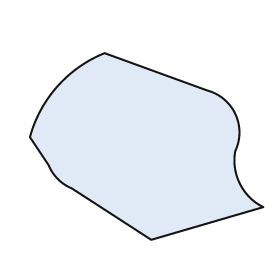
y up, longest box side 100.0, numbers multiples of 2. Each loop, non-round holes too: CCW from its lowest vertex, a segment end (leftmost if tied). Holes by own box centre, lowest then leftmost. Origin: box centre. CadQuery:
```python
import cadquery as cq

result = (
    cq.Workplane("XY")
    .moveTo(2.0, -40.0)
    .lineTo(50.0, -26.0)
    .threePointArc((40.0, -16.0), (38.0, -2.0))
    .threePointArc((38.0, 14.0), (26.0, 24.0))
    .lineTo(-18.0, 40.0)
    .threePointArc((-38.0, 26.0), (-50.0, 4.0))
    .lineTo(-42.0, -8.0)
    .threePointArc((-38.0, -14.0), (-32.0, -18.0))
    .close()
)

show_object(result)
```